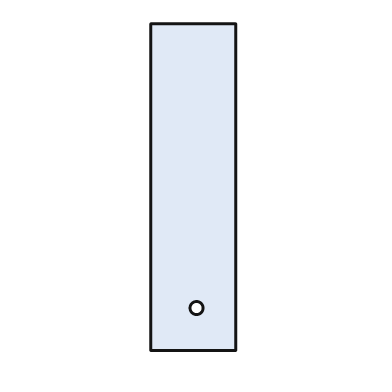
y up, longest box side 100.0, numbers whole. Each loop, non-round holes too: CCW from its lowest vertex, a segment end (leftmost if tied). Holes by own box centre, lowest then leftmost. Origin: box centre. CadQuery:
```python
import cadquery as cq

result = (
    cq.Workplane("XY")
    .moveTo(-13.0, -50.0)
    .lineTo(13.0, -50.0)
    .lineTo(13.0, 50.0)
    .lineTo(-13.0, 50.0)
    .close()
    .moveTo(1.0, -37.0)
    .circle(2.0)
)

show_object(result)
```